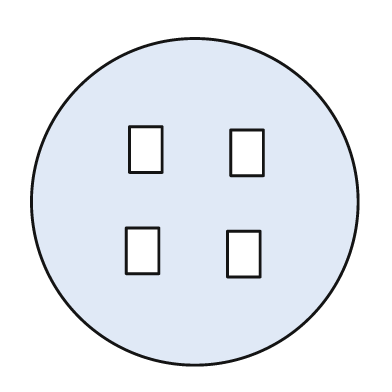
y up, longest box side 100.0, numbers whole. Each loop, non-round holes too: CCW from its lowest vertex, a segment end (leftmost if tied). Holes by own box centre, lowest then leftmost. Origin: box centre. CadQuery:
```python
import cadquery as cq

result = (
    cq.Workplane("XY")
    .moveTo(0.0, 0.0)
    .circle(50.0)
    .moveTo(10.0, -23.0)
    .lineTo(20.0, -23.0)
    .lineTo(20.0, -9.0)
    .lineTo(10.0, -9.0)
    .close()
    .moveTo(-21.0, -22.0)
    .lineTo(-11.0, -22.0)
    .lineTo(-11.0, -8.0)
    .lineTo(-21.0, -8.0)
    .close()
    .moveTo(11.0, 8.0)
    .lineTo(21.0, 8.0)
    .lineTo(21.0, 22.0)
    .lineTo(11.0, 22.0)
    .close()
    .moveTo(-20.0, 9.0)
    .lineTo(-10.0, 9.0)
    .lineTo(-10.0, 23.0)
    .lineTo(-20.0, 23.0)
    .close()
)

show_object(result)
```